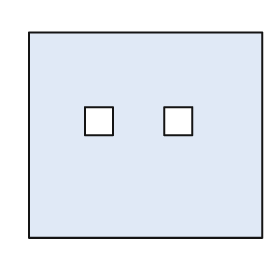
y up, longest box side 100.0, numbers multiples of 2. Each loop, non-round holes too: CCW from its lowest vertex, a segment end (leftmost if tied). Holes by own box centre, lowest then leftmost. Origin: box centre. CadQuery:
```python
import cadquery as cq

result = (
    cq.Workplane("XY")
    .moveTo(-50.0, -44.0)
    .lineTo(50.0, -44.0)
    .lineTo(50.0, 44.0)
    .lineTo(-50.0, 44.0)
    .close()
    .moveTo(-26.0, 0.0)
    .lineTo(-14.0, 0.0)
    .lineTo(-14.0, 12.0)
    .lineTo(-26.0, 12.0)
    .close()
    .moveTo(8.0, 0.0)
    .lineTo(20.0, 0.0)
    .lineTo(20.0, 12.0)
    .lineTo(8.0, 12.0)
    .close()
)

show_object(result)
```